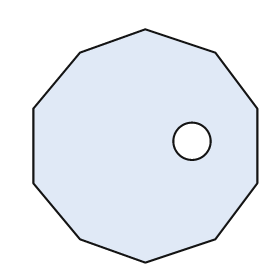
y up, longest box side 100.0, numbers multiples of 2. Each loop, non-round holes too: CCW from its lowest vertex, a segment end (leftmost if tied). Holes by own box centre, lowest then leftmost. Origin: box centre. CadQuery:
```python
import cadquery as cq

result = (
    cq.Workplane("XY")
    .moveTo(0.0, -50.0)
    .lineTo(30.0, -40.0)
    .lineTo(48.0, -16.0)
    .lineTo(48.0, 16.0)
    .lineTo(30.0, 40.0)
    .lineTo(0.0, 50.0)
    .lineTo(-28.0, 40.0)
    .lineTo(-48.0, 16.0)
    .lineTo(-48.0, -16.0)
    .lineTo(-28.0, -40.0)
    .close()
    .moveTo(20.0, 2.0)
    .circle(8.0)
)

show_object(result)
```